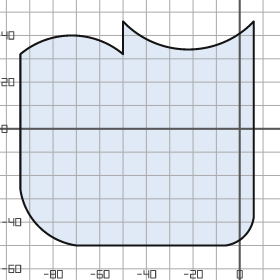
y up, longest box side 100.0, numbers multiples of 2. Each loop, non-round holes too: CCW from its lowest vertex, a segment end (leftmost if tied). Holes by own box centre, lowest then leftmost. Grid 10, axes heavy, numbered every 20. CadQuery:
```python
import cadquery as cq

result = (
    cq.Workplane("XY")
    .moveTo(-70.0, -50.0)
    .lineTo(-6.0, -50.0)
    .threePointArc((2.0, -46.0), (6.0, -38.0))
    .lineTo(6.0, 46.0)
    .threePointArc((-22.0, 34.0), (-50.0, 46.0))
    .lineTo(-50.0, 32.0)
    .threePointArc((-72.0, 40.0), (-94.0, 32.0))
    .lineTo(-94.0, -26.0)
    .threePointArc((-86.0, -42.0), (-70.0, -50.0))
    .close()
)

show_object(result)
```